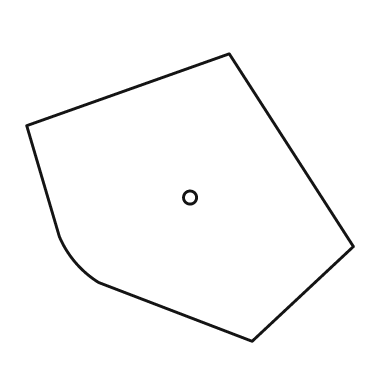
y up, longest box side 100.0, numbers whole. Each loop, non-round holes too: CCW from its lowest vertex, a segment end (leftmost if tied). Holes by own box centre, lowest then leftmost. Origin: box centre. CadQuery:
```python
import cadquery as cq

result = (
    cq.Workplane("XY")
    .moveTo(19.0, -44.0)
    .lineTo(50.0, -15.0)
    .lineTo(12.0, 44.0)
    .lineTo(-50.0, 22.0)
    .lineTo(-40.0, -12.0)
    .threePointArc((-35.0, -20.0), (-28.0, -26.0))
    .close()
    .moveTo(0.0, 0.0)
    .circle(2.0)
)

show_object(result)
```